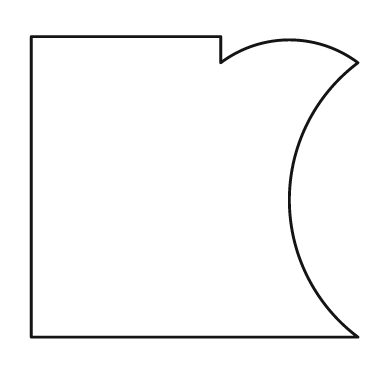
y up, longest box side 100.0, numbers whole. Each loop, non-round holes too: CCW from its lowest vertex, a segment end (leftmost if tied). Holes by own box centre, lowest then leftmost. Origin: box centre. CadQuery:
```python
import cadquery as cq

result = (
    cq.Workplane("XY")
    .moveTo(-50.0, -46.0)
    .lineTo(50.0, -46.0)
    .threePointArc((29.0, -4.0), (50.0, 38.0))
    .threePointArc((29.0, 45.0), (8.0, 38.0))
    .lineTo(8.0, 46.0)
    .lineTo(-50.0, 46.0)
    .close()
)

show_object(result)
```